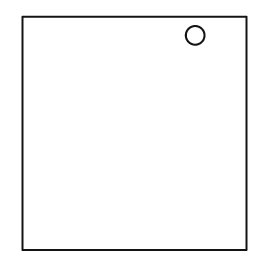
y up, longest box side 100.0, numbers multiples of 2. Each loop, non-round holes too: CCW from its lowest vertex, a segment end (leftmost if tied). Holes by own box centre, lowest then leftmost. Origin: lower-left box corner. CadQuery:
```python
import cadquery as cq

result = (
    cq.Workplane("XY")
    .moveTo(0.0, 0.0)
    .lineTo(96.0, 0.0)
    .lineTo(96.0, 100.0)
    .lineTo(0.0, 100.0)
    .close()
    .moveTo(74.0, 92.0)
    .circle(4.0)
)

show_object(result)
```